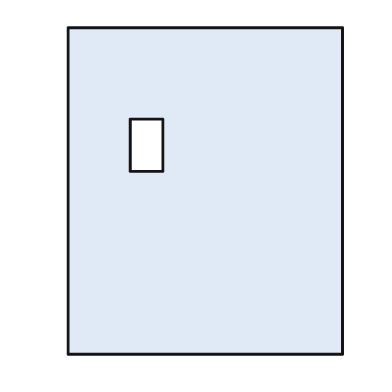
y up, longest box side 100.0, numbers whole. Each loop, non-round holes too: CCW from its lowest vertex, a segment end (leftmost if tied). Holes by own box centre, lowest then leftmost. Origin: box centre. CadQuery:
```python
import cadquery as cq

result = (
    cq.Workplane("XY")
    .moveTo(-42.0, -50.0)
    .lineTo(42.0, -50.0)
    .lineTo(42.0, 50.0)
    .lineTo(-42.0, 50.0)
    .close()
    .moveTo(-23.0, 6.0)
    .lineTo(-13.0, 6.0)
    .lineTo(-13.0, 22.0)
    .lineTo(-23.0, 22.0)
    .close()
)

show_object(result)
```